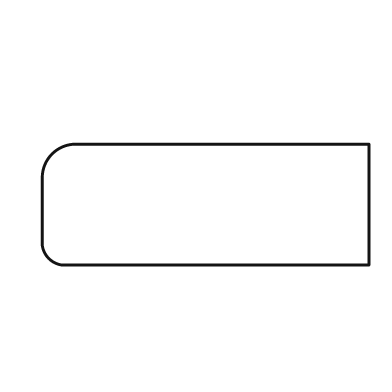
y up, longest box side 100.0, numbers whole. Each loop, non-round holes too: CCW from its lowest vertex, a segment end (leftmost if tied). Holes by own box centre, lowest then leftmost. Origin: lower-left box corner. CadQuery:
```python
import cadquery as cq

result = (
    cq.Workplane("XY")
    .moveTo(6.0, 0.0)
    .lineTo(100.0, 0.0)
    .lineTo(100.0, 37.0)
    .lineTo(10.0, 37.0)
    .threePointArc((3.0, 34.0), (0.0, 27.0))
    .lineTo(0.0, 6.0)
    .threePointArc((2.0, 2.0), (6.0, 0.0))
    .close()
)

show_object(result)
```